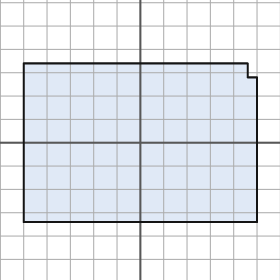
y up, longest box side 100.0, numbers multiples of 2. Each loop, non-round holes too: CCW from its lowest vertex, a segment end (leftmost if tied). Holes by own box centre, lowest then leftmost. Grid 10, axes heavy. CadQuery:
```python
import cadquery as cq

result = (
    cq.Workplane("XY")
    .moveTo(-50.0, -34.0)
    .lineTo(50.0, -34.0)
    .lineTo(50.0, 28.0)
    .lineTo(46.0, 28.0)
    .lineTo(46.0, 34.0)
    .lineTo(-50.0, 34.0)
    .close()
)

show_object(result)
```